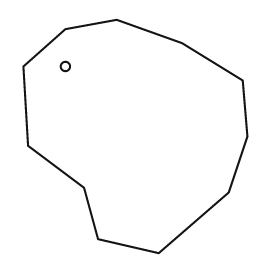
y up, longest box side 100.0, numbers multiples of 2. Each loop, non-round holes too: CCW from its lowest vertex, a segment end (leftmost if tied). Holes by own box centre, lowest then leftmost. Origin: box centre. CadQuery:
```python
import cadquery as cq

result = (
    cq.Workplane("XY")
    .moveTo(10.0, -50.0)
    .lineTo(40.0, -24.0)
    .lineTo(48.0, 0.0)
    .lineTo(46.0, 24.0)
    .lineTo(20.0, 40.0)
    .lineTo(-8.0, 50.0)
    .lineTo(-30.0, 46.0)
    .lineTo(-48.0, 30.0)
    .lineTo(-46.0, -4.0)
    .lineTo(-22.0, -22.0)
    .lineTo(-16.0, -44.0)
    .close()
    .moveTo(-30.0, 30.0)
    .circle(2.0)
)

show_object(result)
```